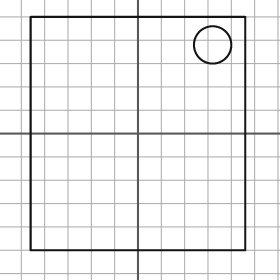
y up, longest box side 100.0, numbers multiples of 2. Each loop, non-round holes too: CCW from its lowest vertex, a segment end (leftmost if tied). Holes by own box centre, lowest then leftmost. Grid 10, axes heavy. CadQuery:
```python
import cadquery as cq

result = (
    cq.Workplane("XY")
    .moveTo(-46.0, -50.0)
    .lineTo(46.0, -50.0)
    .lineTo(46.0, 50.0)
    .lineTo(-46.0, 50.0)
    .close()
    .moveTo(32.0, 38.0)
    .circle(8.0)
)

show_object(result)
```